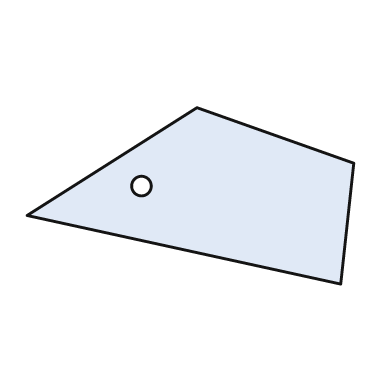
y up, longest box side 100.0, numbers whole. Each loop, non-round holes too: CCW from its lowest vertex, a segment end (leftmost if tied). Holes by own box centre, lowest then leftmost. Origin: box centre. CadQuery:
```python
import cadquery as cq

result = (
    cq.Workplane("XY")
    .moveTo(46.0, -27.0)
    .lineTo(50.0, 10.0)
    .lineTo(2.0, 27.0)
    .lineTo(-50.0, -6.0)
    .close()
    .moveTo(-15.0, 3.0)
    .circle(3.0)
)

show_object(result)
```